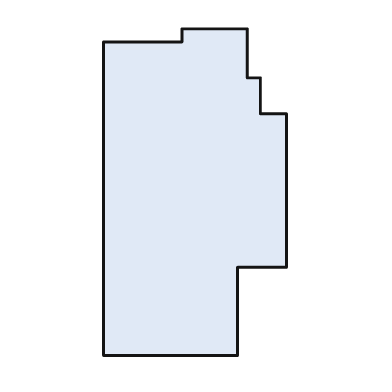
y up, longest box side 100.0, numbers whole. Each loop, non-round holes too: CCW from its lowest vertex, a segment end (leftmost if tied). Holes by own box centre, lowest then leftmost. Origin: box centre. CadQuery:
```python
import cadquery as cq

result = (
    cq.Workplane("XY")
    .moveTo(-28.0, -50.0)
    .lineTo(13.0, -50.0)
    .lineTo(13.0, -23.0)
    .lineTo(28.0, -23.0)
    .lineTo(28.0, 24.0)
    .lineTo(20.0, 24.0)
    .lineTo(20.0, 35.0)
    .lineTo(16.0, 35.0)
    .lineTo(16.0, 50.0)
    .lineTo(-4.0, 50.0)
    .lineTo(-4.0, 46.0)
    .lineTo(-28.0, 46.0)
    .close()
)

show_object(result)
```